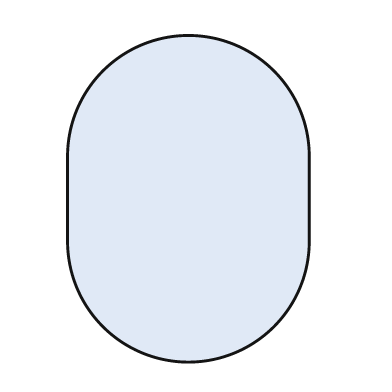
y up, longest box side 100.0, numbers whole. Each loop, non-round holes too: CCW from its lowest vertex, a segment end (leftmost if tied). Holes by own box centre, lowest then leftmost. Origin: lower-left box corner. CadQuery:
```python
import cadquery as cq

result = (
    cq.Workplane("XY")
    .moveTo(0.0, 37.0)
    .threePointArc((37.0, 0.0), (74.0, 37.0))
    .lineTo(74.0, 63.0)
    .threePointArc((37.0, 100.0), (0.0, 63.0))
    .close()
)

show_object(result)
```